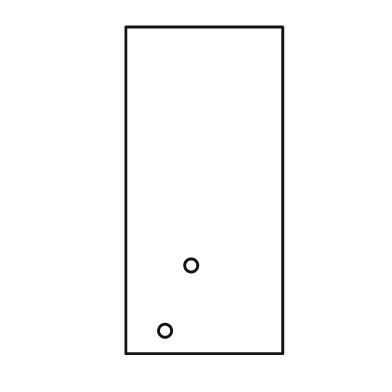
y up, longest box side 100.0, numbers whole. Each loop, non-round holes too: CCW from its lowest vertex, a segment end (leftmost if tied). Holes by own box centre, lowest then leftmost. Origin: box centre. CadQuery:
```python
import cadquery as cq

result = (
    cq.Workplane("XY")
    .moveTo(-24.0, -50.0)
    .lineTo(24.0, -50.0)
    .lineTo(24.0, 50.0)
    .lineTo(-24.0, 50.0)
    .close()
    .moveTo(-12.0, -43.0)
    .circle(2.0)
    .moveTo(-4.0, -23.0)
    .circle(2.0)
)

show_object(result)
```